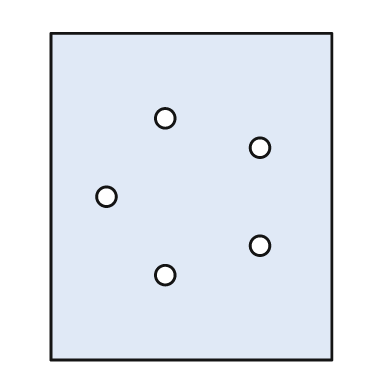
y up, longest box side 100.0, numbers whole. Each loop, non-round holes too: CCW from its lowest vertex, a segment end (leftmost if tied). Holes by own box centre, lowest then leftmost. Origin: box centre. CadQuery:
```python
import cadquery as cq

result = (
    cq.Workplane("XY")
    .moveTo(-43.0, -50.0)
    .lineTo(43.0, -50.0)
    .lineTo(43.0, 50.0)
    .lineTo(-43.0, 50.0)
    .close()
    .moveTo(-8.0, -24.0)
    .circle(3.0)
    .moveTo(21.0, -15.0)
    .circle(3.0)
    .moveTo(-26.0, 0.0)
    .circle(3.0)
    .moveTo(21.0, 15.0)
    .circle(3.0)
    .moveTo(-8.0, 24.0)
    .circle(3.0)
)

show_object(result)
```